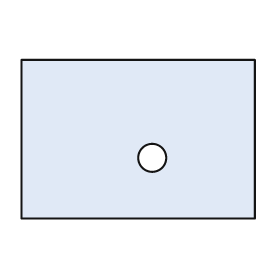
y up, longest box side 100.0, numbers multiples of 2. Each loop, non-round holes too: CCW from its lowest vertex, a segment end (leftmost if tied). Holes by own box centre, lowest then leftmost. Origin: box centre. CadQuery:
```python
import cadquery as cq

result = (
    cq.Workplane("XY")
    .moveTo(-50.0, -34.0)
    .lineTo(50.0, -34.0)
    .lineTo(50.0, 34.0)
    .lineTo(-50.0, 34.0)
    .close()
    .moveTo(6.0, -8.0)
    .circle(6.0)
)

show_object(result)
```